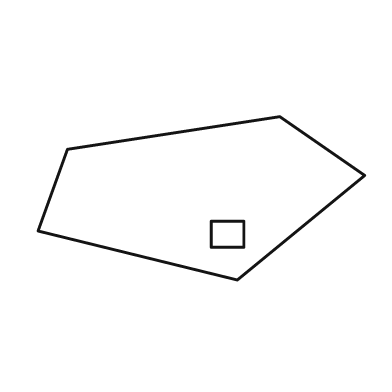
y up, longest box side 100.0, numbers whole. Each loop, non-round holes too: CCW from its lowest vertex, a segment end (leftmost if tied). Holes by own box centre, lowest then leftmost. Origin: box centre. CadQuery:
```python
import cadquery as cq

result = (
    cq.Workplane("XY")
    .moveTo(11.0, -25.0)
    .lineTo(50.0, 7.0)
    .lineTo(24.0, 25.0)
    .lineTo(-41.0, 15.0)
    .lineTo(-50.0, -10.0)
    .close()
    .moveTo(3.0, -15.0)
    .lineTo(13.0, -15.0)
    .lineTo(13.0, -7.0)
    .lineTo(3.0, -7.0)
    .close()
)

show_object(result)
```